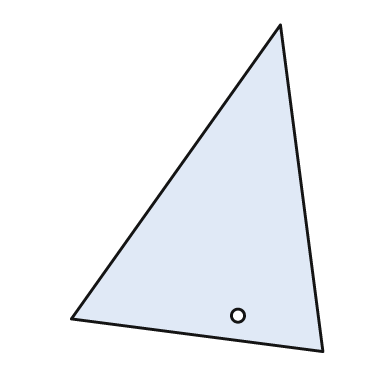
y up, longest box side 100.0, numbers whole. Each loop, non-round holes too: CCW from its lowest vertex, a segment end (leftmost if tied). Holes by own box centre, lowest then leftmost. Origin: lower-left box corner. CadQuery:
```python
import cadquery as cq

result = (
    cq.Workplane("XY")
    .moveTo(77.0, 0.0)
    .lineTo(64.0, 100.0)
    .lineTo(0.0, 10.0)
    .close()
    .moveTo(51.0, 11.0)
    .circle(2.0)
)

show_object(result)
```